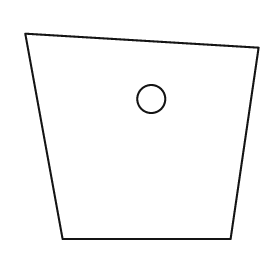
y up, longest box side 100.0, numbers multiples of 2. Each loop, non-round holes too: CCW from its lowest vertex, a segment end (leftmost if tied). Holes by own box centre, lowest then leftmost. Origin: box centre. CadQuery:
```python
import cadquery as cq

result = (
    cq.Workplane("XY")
    .moveTo(-34.0, -44.0)
    .lineTo(38.0, -44.0)
    .lineTo(50.0, 38.0)
    .lineTo(-50.0, 44.0)
    .close()
    .moveTo(4.0, 16.0)
    .circle(6.0)
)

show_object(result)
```